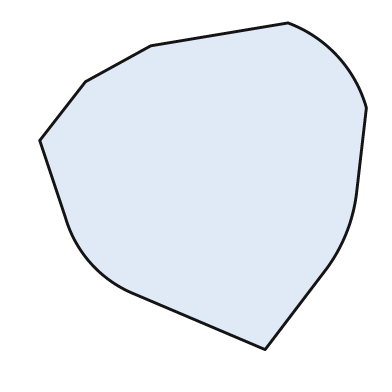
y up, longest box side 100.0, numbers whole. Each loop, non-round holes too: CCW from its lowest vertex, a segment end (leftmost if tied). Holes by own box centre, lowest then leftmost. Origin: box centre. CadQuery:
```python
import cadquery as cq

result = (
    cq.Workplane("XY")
    .moveTo(19.0, -50.0)
    .lineTo(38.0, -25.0)
    .threePointArc((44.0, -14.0), (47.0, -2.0))
    .lineTo(50.0, 24.0)
    .threePointArc((41.0, 40.0), (26.0, 50.0))
    .lineTo(-16.0, 43.0)
    .lineTo(-36.0, 32.0)
    .lineTo(-50.0, 14.0)
    .lineTo(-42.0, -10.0)
    .threePointArc((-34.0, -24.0), (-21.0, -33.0))
    .close()
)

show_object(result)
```